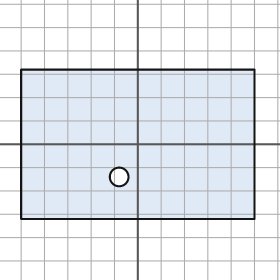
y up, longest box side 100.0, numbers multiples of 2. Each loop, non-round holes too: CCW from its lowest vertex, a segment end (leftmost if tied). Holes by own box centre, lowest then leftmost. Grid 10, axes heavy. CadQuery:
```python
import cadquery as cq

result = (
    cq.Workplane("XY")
    .moveTo(-50.0, -32.0)
    .lineTo(50.0, -32.0)
    .lineTo(50.0, 32.0)
    .lineTo(-50.0, 32.0)
    .close()
    .moveTo(-8.0, -14.0)
    .circle(4.0)
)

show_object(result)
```